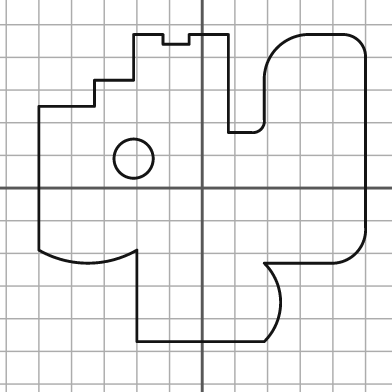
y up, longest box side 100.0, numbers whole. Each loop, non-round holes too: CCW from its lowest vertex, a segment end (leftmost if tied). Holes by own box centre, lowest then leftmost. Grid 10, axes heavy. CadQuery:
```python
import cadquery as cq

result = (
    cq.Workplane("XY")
    .moveTo(-20.0, -47.0)
    .lineTo(19.0, -47.0)
    .threePointArc((24.0, -35.0), (19.0, -23.0))
    .lineTo(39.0, -23.0)
    .threePointArc((47.0, -20.0), (50.0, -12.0))
    .lineTo(50.0, 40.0)
    .threePointArc((48.0, 45.0), (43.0, 47.0))
    .lineTo(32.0, 47.0)
    .threePointArc((23.0, 43.0), (19.0, 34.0))
    .lineTo(19.0, 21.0)
    .threePointArc((18.0, 18.0), (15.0, 17.0))
    .lineTo(8.0, 17.0)
    .lineTo(8.0, 47.0)
    .lineTo(-4.0, 47.0)
    .lineTo(-4.0, 44.0)
    .lineTo(-12.0, 44.0)
    .lineTo(-12.0, 47.0)
    .lineTo(-21.0, 47.0)
    .lineTo(-21.0, 33.0)
    .lineTo(-33.0, 33.0)
    .lineTo(-33.0, 25.0)
    .lineTo(-50.0, 25.0)
    .lineTo(-50.0, -19.0)
    .threePointArc((-35.0, -23.0), (-20.0, -19.0))
    .close()
    .moveTo(-21.0, 9.0)
    .circle(6.0)
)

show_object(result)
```